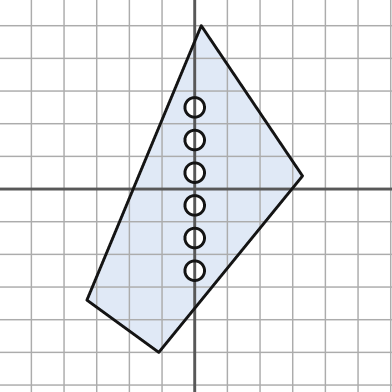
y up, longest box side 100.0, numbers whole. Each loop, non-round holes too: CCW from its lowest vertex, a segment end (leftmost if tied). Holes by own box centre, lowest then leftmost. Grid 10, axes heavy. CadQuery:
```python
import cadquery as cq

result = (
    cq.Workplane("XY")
    .moveTo(-11.0, -50.0)
    .lineTo(33.0, 4.0)
    .lineTo(2.0, 50.0)
    .lineTo(-33.0, -34.0)
    .close()
    .moveTo(0.0, -25.0)
    .circle(3.0)
    .moveTo(0.0, -15.0)
    .circle(3.0)
    .moveTo(0.0, -5.0)
    .circle(3.0)
    .moveTo(0.0, 5.0)
    .circle(3.0)
    .moveTo(0.0, 15.0)
    .circle(3.0)
    .moveTo(0.0, 25.0)
    .circle(3.0)
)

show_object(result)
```